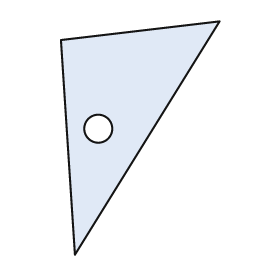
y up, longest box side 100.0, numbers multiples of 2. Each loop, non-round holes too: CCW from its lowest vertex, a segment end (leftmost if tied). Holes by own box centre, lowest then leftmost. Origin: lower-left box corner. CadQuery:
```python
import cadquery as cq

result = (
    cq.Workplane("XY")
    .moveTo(6.0, 0.0)
    .lineTo(68.0, 100.0)
    .lineTo(0.0, 92.0)
    .close()
    .moveTo(16.0, 54.0)
    .circle(6.0)
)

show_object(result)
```